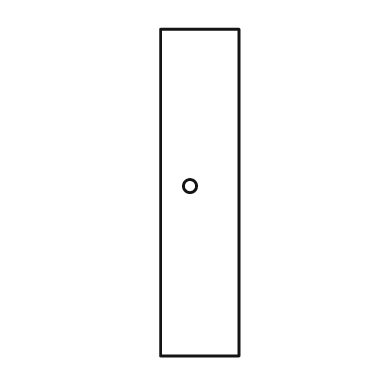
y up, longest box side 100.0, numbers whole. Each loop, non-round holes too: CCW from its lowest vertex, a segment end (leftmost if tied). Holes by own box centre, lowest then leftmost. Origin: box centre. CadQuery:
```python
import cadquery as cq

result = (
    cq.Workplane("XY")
    .moveTo(-12.0, -50.0)
    .lineTo(12.0, -50.0)
    .lineTo(12.0, 50.0)
    .lineTo(-12.0, 50.0)
    .close()
    .moveTo(-3.0, 2.0)
    .circle(2.0)
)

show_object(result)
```